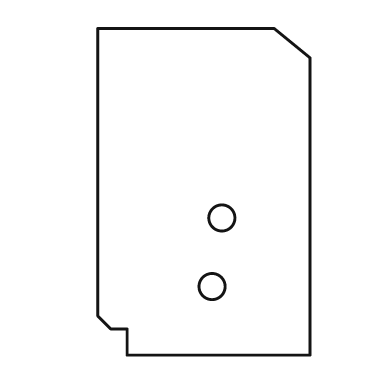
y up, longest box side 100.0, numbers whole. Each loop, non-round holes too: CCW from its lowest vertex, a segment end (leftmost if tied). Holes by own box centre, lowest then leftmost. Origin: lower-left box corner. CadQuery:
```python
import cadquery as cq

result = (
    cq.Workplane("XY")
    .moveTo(9.0, 0.0)
    .lineTo(65.0, 0.0)
    .lineTo(65.0, 91.0)
    .lineTo(54.0, 100.0)
    .lineTo(0.0, 100.0)
    .lineTo(0.0, 12.0)
    .lineTo(4.0, 8.0)
    .lineTo(9.0, 8.0)
    .close()
    .moveTo(35.0, 21.0)
    .circle(4.0)
    .moveTo(38.0, 42.0)
    .circle(4.0)
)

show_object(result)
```